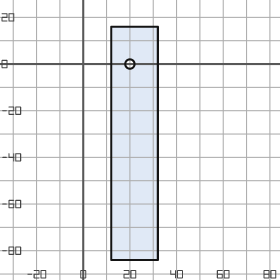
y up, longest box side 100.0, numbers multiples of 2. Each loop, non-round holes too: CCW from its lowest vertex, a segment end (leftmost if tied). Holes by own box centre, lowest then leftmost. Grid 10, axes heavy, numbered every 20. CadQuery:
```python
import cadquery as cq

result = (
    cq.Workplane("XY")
    .moveTo(12.0, -84.0)
    .lineTo(32.0, -84.0)
    .lineTo(32.0, 16.0)
    .lineTo(12.0, 16.0)
    .close()
    .moveTo(20.0, 0.0)
    .circle(2.0)
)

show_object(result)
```